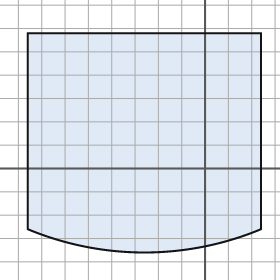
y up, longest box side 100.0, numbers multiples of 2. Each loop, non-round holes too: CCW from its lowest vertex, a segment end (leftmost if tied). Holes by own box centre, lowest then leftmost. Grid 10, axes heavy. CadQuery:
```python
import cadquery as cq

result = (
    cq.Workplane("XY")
    .moveTo(-76.0, -26.0)
    .threePointArc((-26.0, -36.0), (24.0, -26.0))
    .lineTo(24.0, 58.0)
    .lineTo(-76.0, 58.0)
    .close()
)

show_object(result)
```